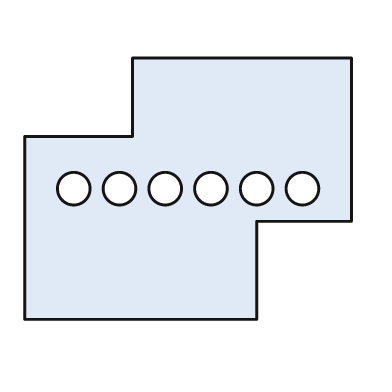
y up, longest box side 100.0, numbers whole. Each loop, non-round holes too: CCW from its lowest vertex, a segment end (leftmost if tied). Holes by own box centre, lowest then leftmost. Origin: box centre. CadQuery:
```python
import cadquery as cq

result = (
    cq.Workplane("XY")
    .moveTo(-50.0, -40.0)
    .lineTo(21.0, -40.0)
    .lineTo(21.0, -10.0)
    .lineTo(50.0, -10.0)
    .lineTo(50.0, 40.0)
    .lineTo(-17.0, 40.0)
    .lineTo(-17.0, 16.0)
    .lineTo(-50.0, 16.0)
    .close()
    .moveTo(-35.0, 0.0)
    .circle(5.0)
    .moveTo(-21.0, 0.0)
    .circle(5.0)
    .moveTo(-7.0, 0.0)
    .circle(5.0)
    .moveTo(7.0, 0.0)
    .circle(5.0)
    .moveTo(21.0, 0.0)
    .circle(5.0)
    .moveTo(35.0, 0.0)
    .circle(5.0)
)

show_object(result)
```